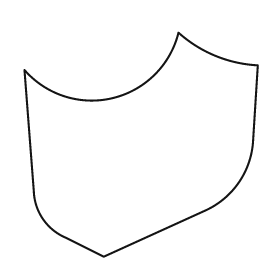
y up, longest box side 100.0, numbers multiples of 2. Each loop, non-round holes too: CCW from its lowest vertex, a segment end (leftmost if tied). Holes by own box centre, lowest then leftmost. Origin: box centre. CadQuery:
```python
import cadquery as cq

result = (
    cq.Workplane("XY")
    .moveTo(-16.0, -48.0)
    .lineTo(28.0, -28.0)
    .threePointArc((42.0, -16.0), (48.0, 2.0))
    .lineTo(50.0, 34.0)
    .threePointArc((32.0, 38.0), (16.0, 48.0))
    .threePointArc((-12.0, 20.0), (-50.0, 32.0))
    .lineTo(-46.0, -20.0)
    .threePointArc((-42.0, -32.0), (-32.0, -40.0))
    .close()
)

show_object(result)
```